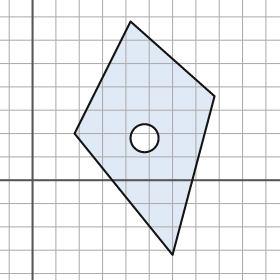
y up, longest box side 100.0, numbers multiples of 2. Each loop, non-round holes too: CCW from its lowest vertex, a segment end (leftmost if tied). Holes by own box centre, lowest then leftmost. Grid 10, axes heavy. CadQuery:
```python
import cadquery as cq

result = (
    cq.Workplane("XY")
    .moveTo(60.0, -32.0)
    .lineTo(78.0, 36.0)
    .lineTo(42.0, 68.0)
    .lineTo(18.0, 20.0)
    .close()
    .moveTo(48.0, 18.0)
    .circle(6.0)
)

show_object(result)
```